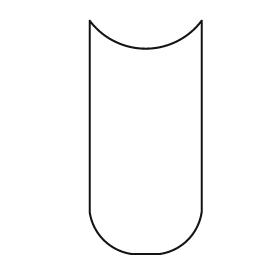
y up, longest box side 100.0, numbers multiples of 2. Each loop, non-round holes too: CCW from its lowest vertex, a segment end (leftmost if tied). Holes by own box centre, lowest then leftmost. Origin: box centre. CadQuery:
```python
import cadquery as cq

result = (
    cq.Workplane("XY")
    .moveTo(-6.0, -50.0)
    .lineTo(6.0, -50.0)
    .threePointArc((18.0, -44.0), (24.0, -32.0))
    .lineTo(24.0, 50.0)
    .threePointArc((0.0, 38.0), (-24.0, 50.0))
    .lineTo(-24.0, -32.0)
    .threePointArc((-18.0, -44.0), (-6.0, -50.0))
    .close()
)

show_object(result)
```